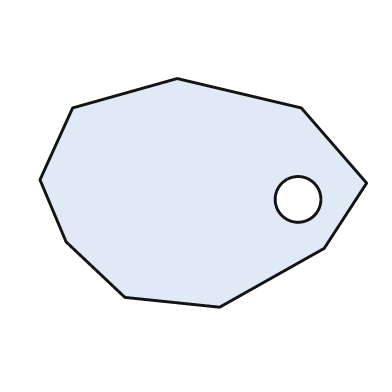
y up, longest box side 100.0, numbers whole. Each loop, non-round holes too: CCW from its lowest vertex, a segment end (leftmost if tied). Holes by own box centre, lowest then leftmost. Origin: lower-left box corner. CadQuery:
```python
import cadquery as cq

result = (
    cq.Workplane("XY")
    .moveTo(55.0, 0.0)
    .lineTo(87.0, 18.0)
    .lineTo(100.0, 38.0)
    .lineTo(80.0, 61.0)
    .lineTo(42.0, 70.0)
    .lineTo(10.0, 61.0)
    .lineTo(0.0, 39.0)
    .lineTo(8.0, 20.0)
    .lineTo(26.0, 3.0)
    .close()
    .moveTo(79.0, 33.0)
    .circle(7.0)
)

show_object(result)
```